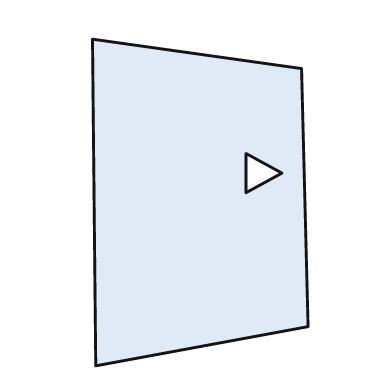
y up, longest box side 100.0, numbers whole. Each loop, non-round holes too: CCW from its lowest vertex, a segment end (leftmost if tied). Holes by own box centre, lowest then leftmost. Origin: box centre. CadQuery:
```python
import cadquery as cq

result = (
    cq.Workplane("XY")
    .moveTo(-32.0, -50.0)
    .lineTo(33.0, -38.0)
    .lineTo(31.0, 41.0)
    .lineTo(-33.0, 50.0)
    .close()
    .moveTo(14.0, 3.0)
    .lineTo(25.0, 9.0)
    .lineTo(14.0, 15.0)
    .close()
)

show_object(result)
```